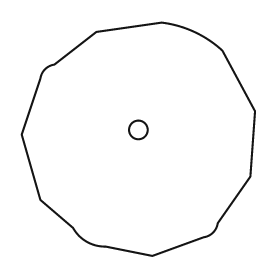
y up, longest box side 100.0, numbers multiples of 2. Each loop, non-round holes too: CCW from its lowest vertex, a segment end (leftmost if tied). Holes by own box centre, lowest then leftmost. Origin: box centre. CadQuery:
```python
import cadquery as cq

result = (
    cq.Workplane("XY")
    .moveTo(6.0, -50.0)
    .lineTo(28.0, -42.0)
    .threePointArc((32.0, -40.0), (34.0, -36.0))
    .lineTo(48.0, -16.0)
    .lineTo(50.0, 12.0)
    .lineTo(36.0, 38.0)
    .threePointArc((24.0, 46.0), (10.0, 50.0))
    .lineTo(-18.0, 46.0)
    .lineTo(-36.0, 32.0)
    .threePointArc((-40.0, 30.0), (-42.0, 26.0))
    .lineTo(-50.0, 2.0)
    .lineTo(-42.0, -26.0)
    .lineTo(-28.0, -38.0)
    .threePointArc((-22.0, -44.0), (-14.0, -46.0))
    .close()
    .moveTo(0.0, 4.0)
    .circle(4.0)
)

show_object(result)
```